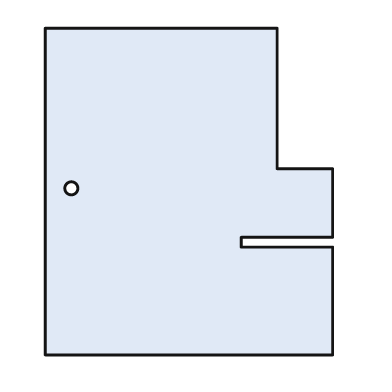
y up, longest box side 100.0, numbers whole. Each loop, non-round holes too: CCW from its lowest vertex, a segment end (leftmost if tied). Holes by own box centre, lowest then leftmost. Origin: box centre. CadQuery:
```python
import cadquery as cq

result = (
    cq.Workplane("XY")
    .moveTo(-44.0, -50.0)
    .lineTo(44.0, -50.0)
    .lineTo(44.0, -17.0)
    .lineTo(16.0, -17.0)
    .lineTo(16.0, -14.0)
    .lineTo(44.0, -14.0)
    .lineTo(44.0, 7.0)
    .lineTo(27.0, 7.0)
    .lineTo(27.0, 50.0)
    .lineTo(-44.0, 50.0)
    .close()
    .moveTo(-36.0, 1.0)
    .circle(2.0)
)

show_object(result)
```